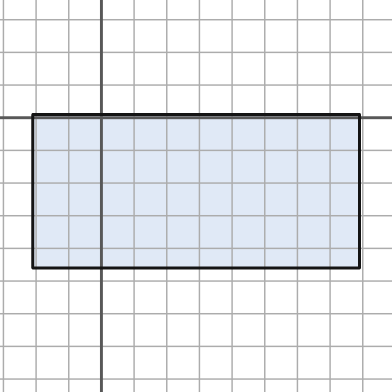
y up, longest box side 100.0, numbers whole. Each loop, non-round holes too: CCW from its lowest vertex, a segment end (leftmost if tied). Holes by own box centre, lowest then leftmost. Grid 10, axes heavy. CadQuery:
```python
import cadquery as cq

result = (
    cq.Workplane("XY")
    .moveTo(-21.0, -46.0)
    .lineTo(79.0, -46.0)
    .lineTo(79.0, 1.0)
    .lineTo(-21.0, 1.0)
    .close()
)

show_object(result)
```